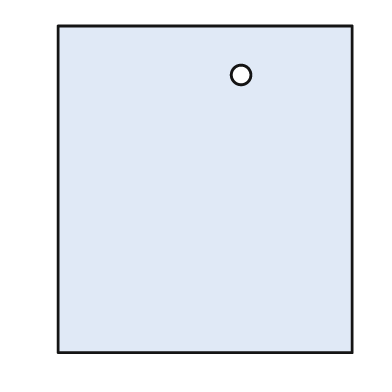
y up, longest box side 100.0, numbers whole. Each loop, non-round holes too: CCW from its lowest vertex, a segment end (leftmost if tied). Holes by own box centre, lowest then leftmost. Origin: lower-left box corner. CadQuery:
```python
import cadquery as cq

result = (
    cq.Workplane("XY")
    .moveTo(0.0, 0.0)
    .lineTo(90.0, 0.0)
    .lineTo(90.0, 100.0)
    .lineTo(0.0, 100.0)
    .close()
    .moveTo(56.0, 85.0)
    .circle(3.0)
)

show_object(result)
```